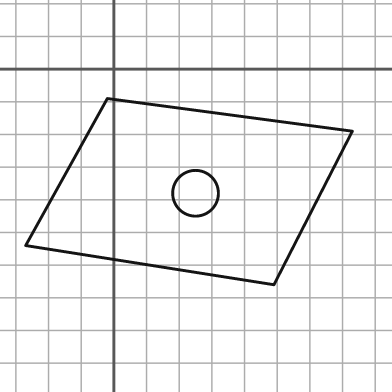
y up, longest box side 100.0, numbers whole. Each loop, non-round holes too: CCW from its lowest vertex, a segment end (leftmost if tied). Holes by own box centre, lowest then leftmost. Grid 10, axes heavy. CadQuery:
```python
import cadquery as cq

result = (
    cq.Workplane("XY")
    .moveTo(49.0, -66.0)
    .lineTo(73.0, -19.0)
    .lineTo(-2.0, -9.0)
    .lineTo(-27.0, -54.0)
    .close()
    .moveTo(25.0, -38.0)
    .circle(7.0)
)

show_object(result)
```